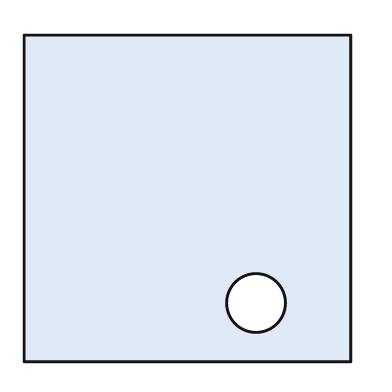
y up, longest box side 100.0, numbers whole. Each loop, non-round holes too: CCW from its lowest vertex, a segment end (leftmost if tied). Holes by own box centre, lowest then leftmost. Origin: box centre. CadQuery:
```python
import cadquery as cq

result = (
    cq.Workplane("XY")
    .moveTo(-50.0, -50.0)
    .lineTo(50.0, -50.0)
    .lineTo(50.0, 50.0)
    .lineTo(-50.0, 50.0)
    .close()
    .moveTo(21.0, -32.0)
    .circle(9.0)
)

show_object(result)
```